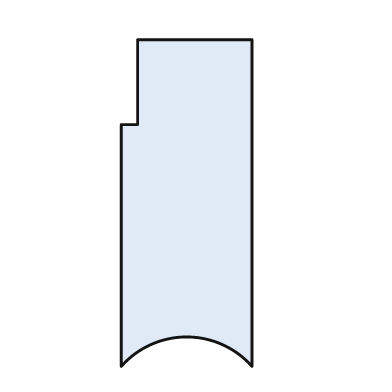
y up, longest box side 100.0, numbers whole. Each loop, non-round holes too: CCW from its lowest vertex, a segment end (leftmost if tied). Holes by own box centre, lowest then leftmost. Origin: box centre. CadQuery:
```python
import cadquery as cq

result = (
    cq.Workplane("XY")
    .moveTo(-20.0, -50.0)
    .threePointArc((0.0, -41.0), (20.0, -50.0))
    .lineTo(20.0, 50.0)
    .lineTo(-15.0, 50.0)
    .lineTo(-15.0, 24.0)
    .lineTo(-20.0, 24.0)
    .close()
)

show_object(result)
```